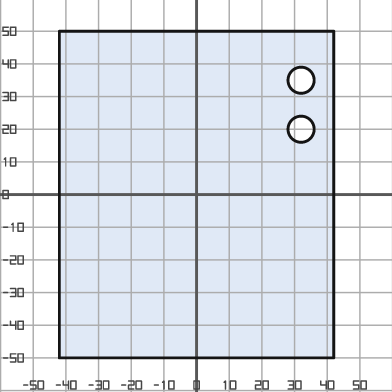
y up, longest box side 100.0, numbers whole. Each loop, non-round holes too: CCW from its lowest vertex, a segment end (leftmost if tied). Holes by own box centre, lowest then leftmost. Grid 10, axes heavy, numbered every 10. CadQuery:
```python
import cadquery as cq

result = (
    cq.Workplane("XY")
    .moveTo(-42.0, -50.0)
    .lineTo(42.0, -50.0)
    .lineTo(42.0, 50.0)
    .lineTo(-42.0, 50.0)
    .close()
    .moveTo(32.0, 20.0)
    .circle(4.0)
    .moveTo(32.0, 35.0)
    .circle(4.0)
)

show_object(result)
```